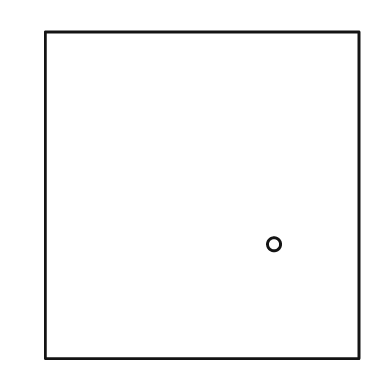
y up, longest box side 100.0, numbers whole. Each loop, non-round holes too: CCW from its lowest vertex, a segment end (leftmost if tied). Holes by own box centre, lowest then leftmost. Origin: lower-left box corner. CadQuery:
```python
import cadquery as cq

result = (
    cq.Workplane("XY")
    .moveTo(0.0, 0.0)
    .lineTo(96.0, 0.0)
    .lineTo(96.0, 100.0)
    .lineTo(0.0, 100.0)
    .close()
    .moveTo(70.0, 35.0)
    .circle(2.0)
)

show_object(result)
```